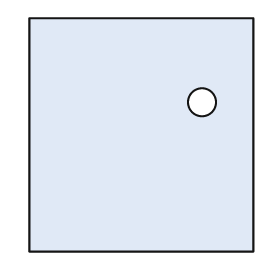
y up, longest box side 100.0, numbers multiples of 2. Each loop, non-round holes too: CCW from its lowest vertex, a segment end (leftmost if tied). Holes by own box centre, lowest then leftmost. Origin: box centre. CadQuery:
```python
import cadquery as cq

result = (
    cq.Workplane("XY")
    .moveTo(-48.0, -50.0)
    .lineTo(48.0, -50.0)
    .lineTo(48.0, 50.0)
    .lineTo(-48.0, 50.0)
    .close()
    .moveTo(26.0, 14.0)
    .circle(6.0)
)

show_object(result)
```